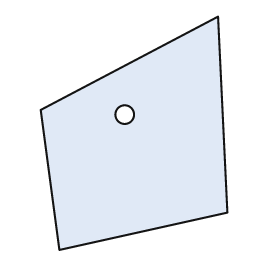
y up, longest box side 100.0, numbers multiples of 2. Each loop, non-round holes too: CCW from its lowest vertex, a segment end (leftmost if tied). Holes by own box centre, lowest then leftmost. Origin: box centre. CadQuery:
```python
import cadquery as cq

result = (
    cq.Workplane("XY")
    .moveTo(-32.0, -50.0)
    .lineTo(40.0, -34.0)
    .lineTo(36.0, 50.0)
    .lineTo(-40.0, 10.0)
    .close()
    .moveTo(-4.0, 8.0)
    .circle(4.0)
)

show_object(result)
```